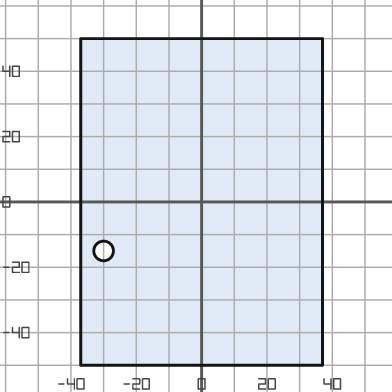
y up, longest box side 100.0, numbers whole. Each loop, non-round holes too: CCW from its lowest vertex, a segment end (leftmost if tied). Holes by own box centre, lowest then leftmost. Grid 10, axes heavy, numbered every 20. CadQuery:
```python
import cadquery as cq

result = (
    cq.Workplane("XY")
    .moveTo(-37.0, -50.0)
    .lineTo(37.0, -50.0)
    .lineTo(37.0, 50.0)
    .lineTo(-37.0, 50.0)
    .close()
    .moveTo(-30.0, -15.0)
    .circle(3.0)
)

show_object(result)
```